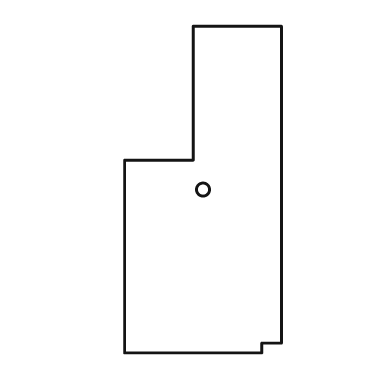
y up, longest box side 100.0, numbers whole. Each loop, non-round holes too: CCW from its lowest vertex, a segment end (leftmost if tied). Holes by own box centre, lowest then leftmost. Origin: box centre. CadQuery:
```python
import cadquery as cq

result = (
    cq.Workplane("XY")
    .moveTo(-24.0, -50.0)
    .lineTo(18.0, -50.0)
    .lineTo(18.0, -47.0)
    .lineTo(24.0, -47.0)
    .lineTo(24.0, 50.0)
    .lineTo(-3.0, 50.0)
    .lineTo(-3.0, 9.0)
    .lineTo(-24.0, 9.0)
    .close()
    .moveTo(0.0, 0.0)
    .circle(2.0)
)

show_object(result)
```